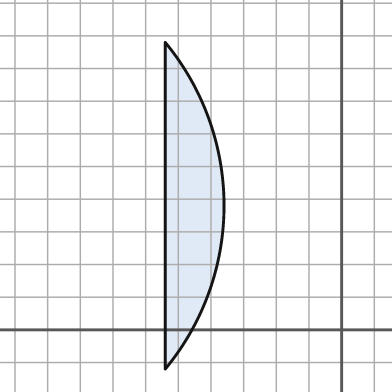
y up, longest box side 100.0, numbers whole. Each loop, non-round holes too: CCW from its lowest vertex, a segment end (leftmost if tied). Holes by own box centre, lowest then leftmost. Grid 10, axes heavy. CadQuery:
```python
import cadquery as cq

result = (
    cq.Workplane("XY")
    .moveTo(-54.0, -12.0)
    .threePointArc((-36.0, 38.0), (-54.0, 88.0))
    .close()
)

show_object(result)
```